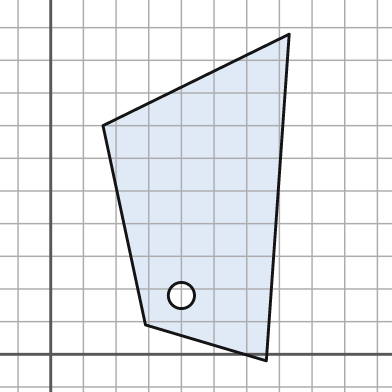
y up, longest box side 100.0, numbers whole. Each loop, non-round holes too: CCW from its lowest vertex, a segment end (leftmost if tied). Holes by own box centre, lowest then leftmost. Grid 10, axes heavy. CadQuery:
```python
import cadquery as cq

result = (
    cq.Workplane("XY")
    .moveTo(66.0, -2.0)
    .lineTo(73.0, 98.0)
    .lineTo(16.0, 70.0)
    .lineTo(29.0, 9.0)
    .close()
    .moveTo(40.0, 18.0)
    .circle(4.0)
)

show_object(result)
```